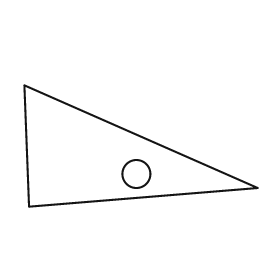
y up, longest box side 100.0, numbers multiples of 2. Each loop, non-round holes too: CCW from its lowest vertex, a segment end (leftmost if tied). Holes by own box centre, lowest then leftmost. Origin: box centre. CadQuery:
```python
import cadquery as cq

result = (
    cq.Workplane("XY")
    .moveTo(-48.0, -26.0)
    .lineTo(50.0, -18.0)
    .lineTo(-50.0, 26.0)
    .close()
    .moveTo(-2.0, -12.0)
    .circle(6.0)
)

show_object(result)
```